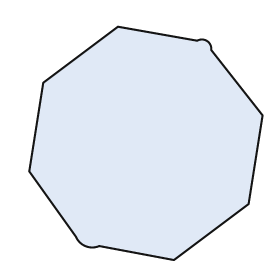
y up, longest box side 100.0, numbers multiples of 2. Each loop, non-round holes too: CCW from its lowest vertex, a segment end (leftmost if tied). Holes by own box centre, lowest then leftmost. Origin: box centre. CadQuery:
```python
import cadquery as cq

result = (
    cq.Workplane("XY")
    .moveTo(12.0, -50.0)
    .lineTo(44.0, -26.0)
    .lineTo(50.0, 12.0)
    .lineTo(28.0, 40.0)
    .threePointArc((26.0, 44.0), (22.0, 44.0))
    .lineTo(-12.0, 50.0)
    .lineTo(-44.0, 26.0)
    .lineTo(-50.0, -12.0)
    .lineTo(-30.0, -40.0)
    .threePointArc((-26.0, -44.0), (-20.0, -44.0))
    .close()
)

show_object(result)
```